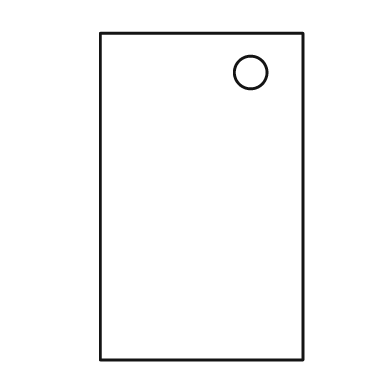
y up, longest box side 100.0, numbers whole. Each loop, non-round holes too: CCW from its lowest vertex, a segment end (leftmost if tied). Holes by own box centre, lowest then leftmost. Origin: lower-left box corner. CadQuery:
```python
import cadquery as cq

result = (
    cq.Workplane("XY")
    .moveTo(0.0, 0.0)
    .lineTo(62.0, 0.0)
    .lineTo(62.0, 100.0)
    .lineTo(0.0, 100.0)
    .close()
    .moveTo(46.0, 88.0)
    .circle(5.0)
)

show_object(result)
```